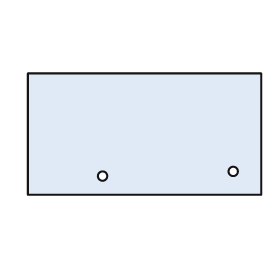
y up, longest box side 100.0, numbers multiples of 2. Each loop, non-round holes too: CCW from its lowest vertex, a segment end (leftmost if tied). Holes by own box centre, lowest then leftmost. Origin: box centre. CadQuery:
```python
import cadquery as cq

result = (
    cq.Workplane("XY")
    .moveTo(-50.0, -26.0)
    .lineTo(50.0, -26.0)
    .lineTo(50.0, 26.0)
    .lineTo(-50.0, 26.0)
    .close()
    .moveTo(-18.0, -18.0)
    .circle(2.0)
    .moveTo(38.0, -16.0)
    .circle(2.0)
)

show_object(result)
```